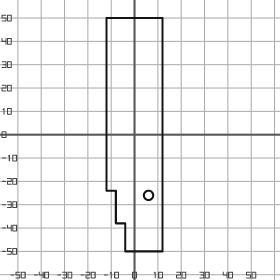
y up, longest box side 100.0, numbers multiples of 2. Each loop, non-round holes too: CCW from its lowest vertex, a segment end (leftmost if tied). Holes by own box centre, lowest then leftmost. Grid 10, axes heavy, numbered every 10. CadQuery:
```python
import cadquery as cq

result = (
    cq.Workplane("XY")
    .moveTo(-4.0, -50.0)
    .lineTo(12.0, -50.0)
    .lineTo(12.0, 50.0)
    .lineTo(-12.0, 50.0)
    .lineTo(-12.0, -24.0)
    .lineTo(-8.0, -24.0)
    .lineTo(-8.0, -38.0)
    .lineTo(-4.0, -38.0)
    .close()
    .moveTo(6.0, -26.0)
    .circle(2.0)
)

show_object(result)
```